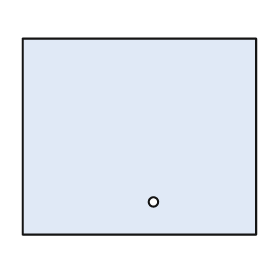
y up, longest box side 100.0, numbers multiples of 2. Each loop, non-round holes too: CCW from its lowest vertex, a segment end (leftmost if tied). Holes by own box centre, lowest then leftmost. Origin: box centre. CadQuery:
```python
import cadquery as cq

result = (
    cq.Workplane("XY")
    .moveTo(-50.0, -42.0)
    .lineTo(50.0, -42.0)
    .lineTo(50.0, 42.0)
    .lineTo(-50.0, 42.0)
    .close()
    .moveTo(6.0, -28.0)
    .circle(2.0)
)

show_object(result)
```